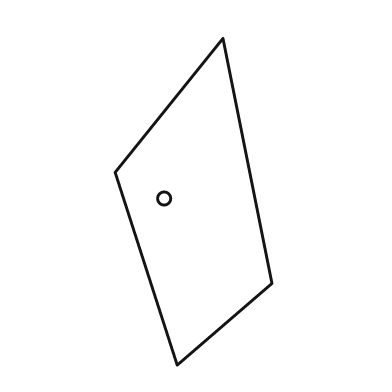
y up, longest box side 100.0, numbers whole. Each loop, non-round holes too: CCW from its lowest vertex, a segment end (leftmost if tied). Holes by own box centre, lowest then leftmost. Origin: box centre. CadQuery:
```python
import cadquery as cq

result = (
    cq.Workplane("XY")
    .moveTo(-5.0, -50.0)
    .lineTo(24.0, -25.0)
    .lineTo(9.0, 50.0)
    .lineTo(-24.0, 9.0)
    .close()
    .moveTo(-9.0, 1.0)
    .circle(2.0)
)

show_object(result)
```